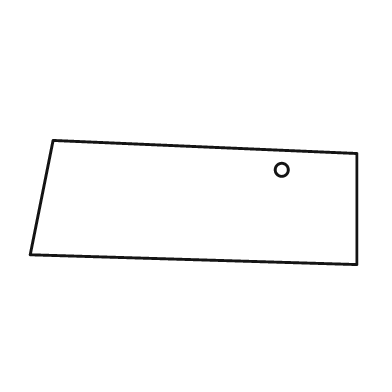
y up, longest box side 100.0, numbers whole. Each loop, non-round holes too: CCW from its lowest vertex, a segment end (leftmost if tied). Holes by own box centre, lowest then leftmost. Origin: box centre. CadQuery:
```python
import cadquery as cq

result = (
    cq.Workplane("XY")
    .moveTo(50.0, -19.0)
    .lineTo(50.0, 15.0)
    .lineTo(-43.0, 19.0)
    .lineTo(-50.0, -16.0)
    .close()
    .moveTo(27.0, 10.0)
    .circle(2.0)
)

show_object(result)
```